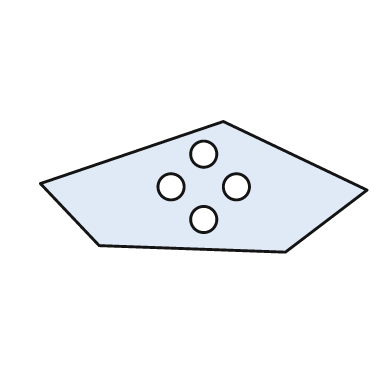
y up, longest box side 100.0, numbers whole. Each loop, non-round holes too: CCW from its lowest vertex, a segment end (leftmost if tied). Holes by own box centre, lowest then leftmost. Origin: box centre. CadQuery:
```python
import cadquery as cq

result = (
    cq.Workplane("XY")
    .moveTo(25.0, -20.0)
    .lineTo(50.0, -1.0)
    .lineTo(6.0, 20.0)
    .lineTo(-50.0, 1.0)
    .lineTo(-32.0, -18.0)
    .close()
    .moveTo(0.0, -10.0)
    .circle(4.0)
    .moveTo(-10.0, 0.0)
    .circle(4.0)
    .moveTo(10.0, 0.0)
    .circle(4.0)
    .moveTo(0.0, 10.0)
    .circle(4.0)
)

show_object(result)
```